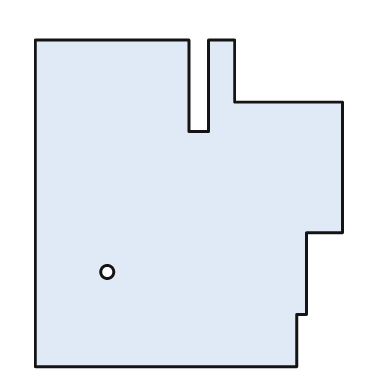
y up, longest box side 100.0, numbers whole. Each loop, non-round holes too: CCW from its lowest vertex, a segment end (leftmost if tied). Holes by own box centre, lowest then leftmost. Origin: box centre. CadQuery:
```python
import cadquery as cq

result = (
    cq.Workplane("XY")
    .moveTo(-47.0, -50.0)
    .lineTo(33.0, -50.0)
    .lineTo(33.0, -34.0)
    .lineTo(36.0, -34.0)
    .lineTo(36.0, -9.0)
    .lineTo(47.0, -9.0)
    .lineTo(47.0, 31.0)
    .lineTo(14.0, 31.0)
    .lineTo(14.0, 50.0)
    .lineTo(6.0, 50.0)
    .lineTo(6.0, 22.0)
    .lineTo(0.0, 22.0)
    .lineTo(0.0, 50.0)
    .lineTo(-47.0, 50.0)
    .close()
    .moveTo(-25.0, -21.0)
    .circle(2.0)
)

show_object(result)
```